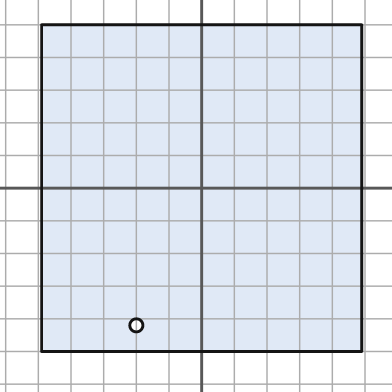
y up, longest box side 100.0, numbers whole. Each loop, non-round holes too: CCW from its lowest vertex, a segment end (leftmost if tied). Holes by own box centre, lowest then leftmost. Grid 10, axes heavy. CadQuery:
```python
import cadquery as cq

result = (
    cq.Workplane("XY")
    .moveTo(-49.0, -50.0)
    .lineTo(49.0, -50.0)
    .lineTo(49.0, 50.0)
    .lineTo(-49.0, 50.0)
    .close()
    .moveTo(-20.0, -42.0)
    .circle(2.0)
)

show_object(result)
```